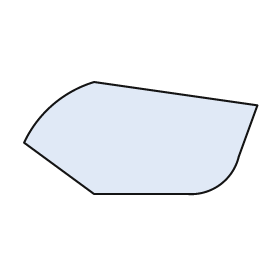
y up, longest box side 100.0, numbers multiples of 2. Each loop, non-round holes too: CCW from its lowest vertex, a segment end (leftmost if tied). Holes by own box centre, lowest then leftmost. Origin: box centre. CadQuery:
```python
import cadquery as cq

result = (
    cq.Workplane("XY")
    .moveTo(-20.0, -24.0)
    .lineTo(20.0, -24.0)
    .threePointArc((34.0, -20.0), (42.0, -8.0))
    .lineTo(50.0, 14.0)
    .lineTo(-20.0, 24.0)
    .threePointArc((-38.0, 14.0), (-50.0, -2.0))
    .close()
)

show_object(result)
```